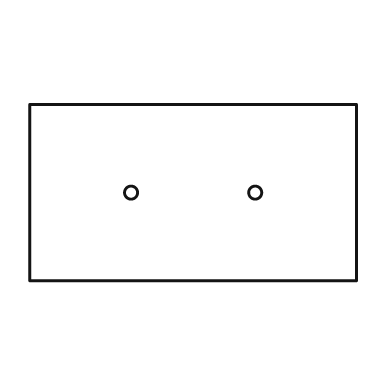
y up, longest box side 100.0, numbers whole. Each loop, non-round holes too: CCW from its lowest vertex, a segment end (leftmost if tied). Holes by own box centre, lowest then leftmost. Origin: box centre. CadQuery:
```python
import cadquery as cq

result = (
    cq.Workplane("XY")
    .moveTo(-50.0, -27.0)
    .lineTo(50.0, -27.0)
    .lineTo(50.0, 27.0)
    .lineTo(-50.0, 27.0)
    .close()
    .moveTo(-19.0, 0.0)
    .circle(2.0)
    .moveTo(19.0, 0.0)
    .circle(2.0)
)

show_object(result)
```